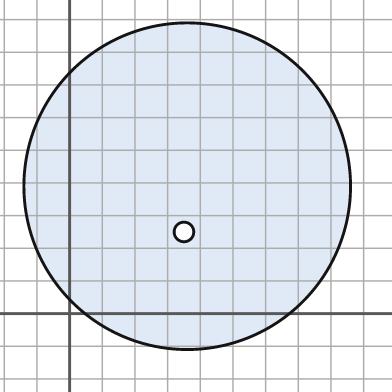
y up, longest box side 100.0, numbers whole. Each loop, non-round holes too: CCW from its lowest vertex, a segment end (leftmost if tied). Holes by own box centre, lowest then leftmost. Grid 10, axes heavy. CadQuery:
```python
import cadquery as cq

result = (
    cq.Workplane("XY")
    .moveTo(36.0, 39.0)
    .circle(50.0)
    .moveTo(35.0, 25.0)
    .circle(3.0)
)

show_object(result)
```